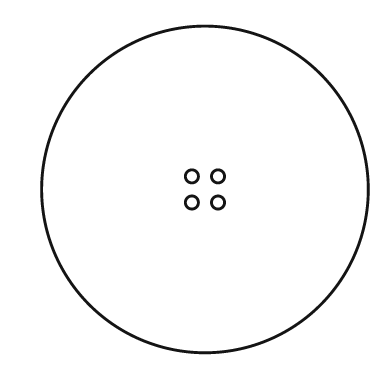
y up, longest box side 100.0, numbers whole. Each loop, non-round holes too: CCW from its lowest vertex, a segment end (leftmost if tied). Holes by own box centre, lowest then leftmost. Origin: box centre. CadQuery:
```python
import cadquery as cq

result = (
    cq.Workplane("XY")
    .moveTo(0.0, 0.0)
    .circle(50.0)
    .moveTo(-4.0, -4.0)
    .circle(2.0)
    .moveTo(4.0, -4.0)
    .circle(2.0)
    .moveTo(-4.0, 4.0)
    .circle(2.0)
    .moveTo(4.0, 4.0)
    .circle(2.0)
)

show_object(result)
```